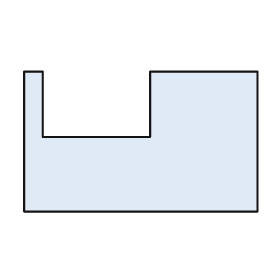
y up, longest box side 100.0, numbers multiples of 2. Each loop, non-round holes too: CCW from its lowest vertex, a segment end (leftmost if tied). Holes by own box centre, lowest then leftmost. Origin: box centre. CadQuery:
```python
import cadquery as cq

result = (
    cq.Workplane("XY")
    .moveTo(-50.0, -30.0)
    .lineTo(50.0, -30.0)
    .lineTo(50.0, 30.0)
    .lineTo(4.0, 30.0)
    .lineTo(4.0, 2.0)
    .lineTo(-42.0, 2.0)
    .lineTo(-42.0, 30.0)
    .lineTo(-50.0, 30.0)
    .close()
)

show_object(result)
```